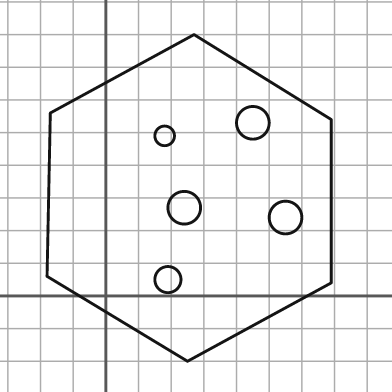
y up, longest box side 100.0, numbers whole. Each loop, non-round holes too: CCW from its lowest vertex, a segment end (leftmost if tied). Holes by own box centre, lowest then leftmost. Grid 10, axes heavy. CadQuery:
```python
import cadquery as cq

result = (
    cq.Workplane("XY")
    .moveTo(25.0, -20.0)
    .lineTo(69.0, 4.0)
    .lineTo(69.0, 54.0)
    .lineTo(27.0, 80.0)
    .lineTo(-17.0, 56.0)
    .lineTo(-18.0, 6.0)
    .close()
    .moveTo(19.0, 5.0)
    .circle(4.0)
    .moveTo(55.0, 24.0)
    .circle(5.0)
    .moveTo(24.0, 27.0)
    .circle(5.0)
    .moveTo(18.0, 49.0)
    .circle(3.0)
    .moveTo(45.0, 53.0)
    .circle(5.0)
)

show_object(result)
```